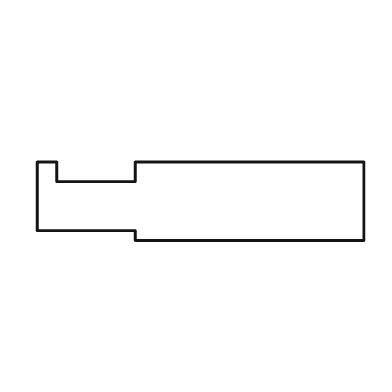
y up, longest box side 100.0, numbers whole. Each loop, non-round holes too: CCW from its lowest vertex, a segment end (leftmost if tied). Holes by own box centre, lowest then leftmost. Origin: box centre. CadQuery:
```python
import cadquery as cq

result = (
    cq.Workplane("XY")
    .moveTo(-20.0, -12.0)
    .lineTo(50.0, -12.0)
    .lineTo(50.0, 12.0)
    .lineTo(-20.0, 12.0)
    .lineTo(-20.0, 6.0)
    .lineTo(-44.0, 6.0)
    .lineTo(-44.0, 12.0)
    .lineTo(-50.0, 12.0)
    .lineTo(-50.0, -9.0)
    .lineTo(-20.0, -9.0)
    .close()
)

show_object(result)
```